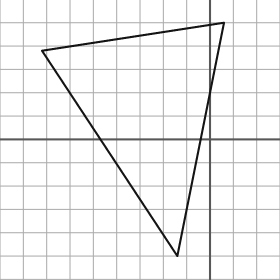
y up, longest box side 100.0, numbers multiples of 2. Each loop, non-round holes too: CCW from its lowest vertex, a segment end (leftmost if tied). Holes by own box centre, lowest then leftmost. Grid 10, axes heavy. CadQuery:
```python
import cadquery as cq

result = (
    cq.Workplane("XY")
    .moveTo(-14.0, -50.0)
    .lineTo(6.0, 50.0)
    .lineTo(-72.0, 38.0)
    .close()
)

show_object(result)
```